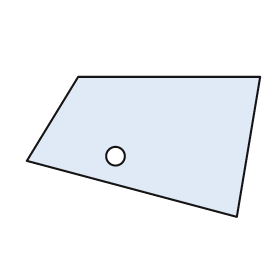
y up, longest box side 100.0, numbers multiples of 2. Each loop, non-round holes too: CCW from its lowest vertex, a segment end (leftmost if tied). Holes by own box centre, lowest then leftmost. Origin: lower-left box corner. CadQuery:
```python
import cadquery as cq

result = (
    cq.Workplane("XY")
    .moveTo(90.0, 0.0)
    .lineTo(100.0, 60.0)
    .lineTo(22.0, 60.0)
    .lineTo(0.0, 24.0)
    .close()
    .moveTo(38.0, 26.0)
    .circle(4.0)
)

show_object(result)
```